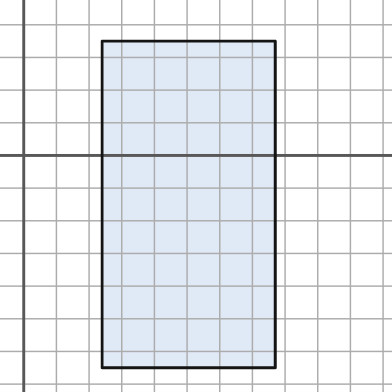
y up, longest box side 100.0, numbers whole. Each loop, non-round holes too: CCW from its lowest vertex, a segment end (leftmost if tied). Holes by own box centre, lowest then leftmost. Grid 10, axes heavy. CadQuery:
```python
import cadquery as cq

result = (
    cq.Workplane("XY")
    .moveTo(24.0, -65.0)
    .lineTo(77.0, -65.0)
    .lineTo(77.0, 35.0)
    .lineTo(24.0, 35.0)
    .close()
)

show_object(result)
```